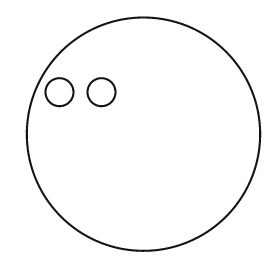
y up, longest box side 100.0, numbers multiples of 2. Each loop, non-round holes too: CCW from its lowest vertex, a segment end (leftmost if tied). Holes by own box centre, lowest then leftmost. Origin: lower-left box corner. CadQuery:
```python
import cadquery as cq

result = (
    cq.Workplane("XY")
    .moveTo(50.0, 50.0)
    .circle(50.0)
    .moveTo(14.0, 68.0)
    .circle(6.0)
    .moveTo(32.0, 68.0)
    .circle(6.0)
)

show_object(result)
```